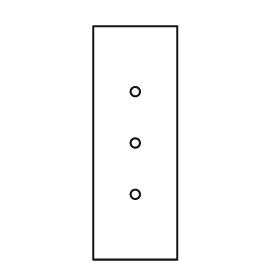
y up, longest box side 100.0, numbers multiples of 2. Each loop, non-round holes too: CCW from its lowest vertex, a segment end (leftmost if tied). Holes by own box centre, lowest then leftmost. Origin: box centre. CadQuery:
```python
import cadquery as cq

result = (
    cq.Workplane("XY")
    .moveTo(-18.0, -50.0)
    .lineTo(18.0, -50.0)
    .lineTo(18.0, 50.0)
    .lineTo(-18.0, 50.0)
    .close()
    .moveTo(0.0, -22.0)
    .circle(2.0)
    .moveTo(0.0, 0.0)
    .circle(2.0)
    .moveTo(0.0, 22.0)
    .circle(2.0)
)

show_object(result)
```